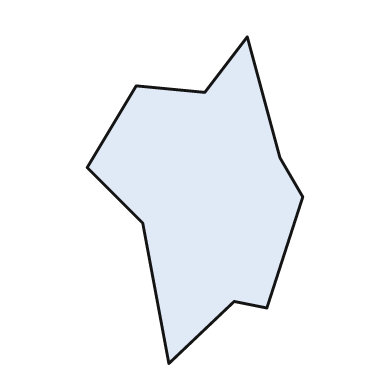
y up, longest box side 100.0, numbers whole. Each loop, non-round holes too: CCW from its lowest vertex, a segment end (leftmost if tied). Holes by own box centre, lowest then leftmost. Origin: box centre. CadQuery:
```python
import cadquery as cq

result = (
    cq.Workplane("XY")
    .moveTo(-8.0, -50.0)
    .lineTo(12.0, -31.0)
    .lineTo(22.0, -33.0)
    .lineTo(33.0, 1.0)
    .lineTo(26.0, 13.0)
    .lineTo(16.0, 50.0)
    .lineTo(3.0, 33.0)
    .lineTo(-18.0, 35.0)
    .lineTo(-33.0, 10.0)
    .lineTo(-16.0, -7.0)
    .close()
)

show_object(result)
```